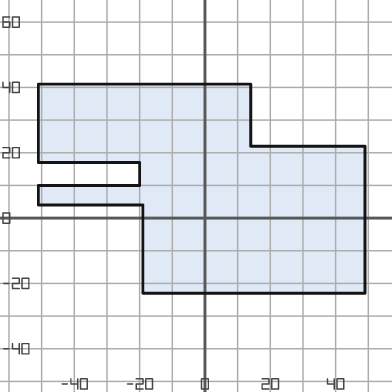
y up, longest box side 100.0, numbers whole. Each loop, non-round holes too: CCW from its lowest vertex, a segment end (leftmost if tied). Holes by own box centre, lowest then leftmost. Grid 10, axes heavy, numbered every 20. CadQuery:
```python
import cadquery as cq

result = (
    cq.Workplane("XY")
    .moveTo(-19.0, -23.0)
    .lineTo(49.0, -23.0)
    .lineTo(49.0, 22.0)
    .lineTo(14.0, 22.0)
    .lineTo(14.0, 41.0)
    .lineTo(-51.0, 41.0)
    .lineTo(-51.0, 17.0)
    .lineTo(-20.0, 17.0)
    .lineTo(-20.0, 10.0)
    .lineTo(-51.0, 10.0)
    .lineTo(-51.0, 4.0)
    .lineTo(-19.0, 4.0)
    .close()
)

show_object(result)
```